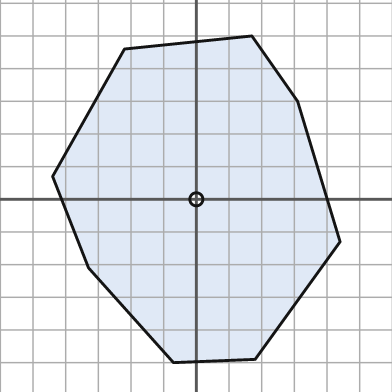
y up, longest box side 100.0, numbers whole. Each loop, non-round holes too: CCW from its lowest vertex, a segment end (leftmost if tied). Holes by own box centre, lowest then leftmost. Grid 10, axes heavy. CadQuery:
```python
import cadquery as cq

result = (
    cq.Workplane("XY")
    .moveTo(-7.0, -50.0)
    .lineTo(18.0, -49.0)
    .lineTo(44.0, -13.0)
    .lineTo(31.0, 30.0)
    .lineTo(17.0, 50.0)
    .lineTo(-22.0, 46.0)
    .lineTo(-44.0, 7.0)
    .lineTo(-33.0, -21.0)
    .close()
    .moveTo(0.0, 0.0)
    .circle(2.0)
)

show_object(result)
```